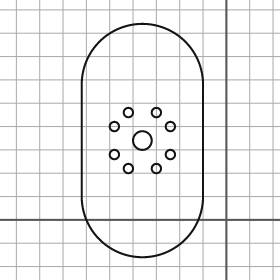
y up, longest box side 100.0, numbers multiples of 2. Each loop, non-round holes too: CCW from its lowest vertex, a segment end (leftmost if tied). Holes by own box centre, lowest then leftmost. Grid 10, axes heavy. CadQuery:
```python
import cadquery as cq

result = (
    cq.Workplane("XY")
    .moveTo(-62.0, 10.0)
    .threePointArc((-36.0, -16.0), (-10.0, 10.0))
    .lineTo(-10.0, 58.0)
    .threePointArc((-36.0, 84.0), (-62.0, 58.0))
    .close()
    .moveTo(-42.0, 22.0)
    .circle(2.0)
    .moveTo(-30.0, 22.0)
    .circle(2.0)
    .moveTo(-48.0, 28.0)
    .circle(2.0)
    .moveTo(-24.0, 28.0)
    .circle(2.0)
    .moveTo(-36.0, 34.0)
    .circle(4.0)
    .moveTo(-48.0, 40.0)
    .circle(2.0)
    .moveTo(-24.0, 40.0)
    .circle(2.0)
    .moveTo(-42.0, 46.0)
    .circle(2.0)
    .moveTo(-30.0, 46.0)
    .circle(2.0)
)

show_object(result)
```